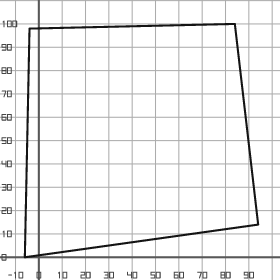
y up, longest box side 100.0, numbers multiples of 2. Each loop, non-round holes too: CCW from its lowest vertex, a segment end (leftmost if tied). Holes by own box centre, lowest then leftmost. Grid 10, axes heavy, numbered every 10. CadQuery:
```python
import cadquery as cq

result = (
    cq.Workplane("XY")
    .moveTo(-6.0, 0.0)
    .lineTo(94.0, 14.0)
    .lineTo(84.0, 100.0)
    .lineTo(-4.0, 98.0)
    .close()
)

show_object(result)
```